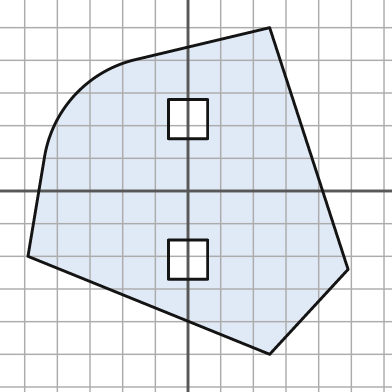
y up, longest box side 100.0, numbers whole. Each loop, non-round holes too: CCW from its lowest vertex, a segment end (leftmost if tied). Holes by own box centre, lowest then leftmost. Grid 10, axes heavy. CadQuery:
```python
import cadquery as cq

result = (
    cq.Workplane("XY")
    .moveTo(25.0, -50.0)
    .lineTo(49.0, -24.0)
    .lineTo(25.0, 50.0)
    .lineTo(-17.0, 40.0)
    .threePointArc((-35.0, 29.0), (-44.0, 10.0))
    .lineTo(-49.0, -20.0)
    .close()
    .moveTo(-6.0, -27.0)
    .lineTo(6.0, -27.0)
    .lineTo(6.0, -15.0)
    .lineTo(-6.0, -15.0)
    .close()
    .moveTo(-6.0, 16.0)
    .lineTo(6.0, 16.0)
    .lineTo(6.0, 28.0)
    .lineTo(-6.0, 28.0)
    .close()
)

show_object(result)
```